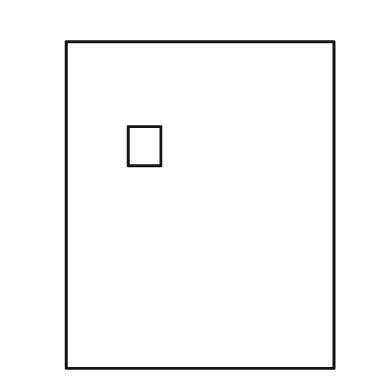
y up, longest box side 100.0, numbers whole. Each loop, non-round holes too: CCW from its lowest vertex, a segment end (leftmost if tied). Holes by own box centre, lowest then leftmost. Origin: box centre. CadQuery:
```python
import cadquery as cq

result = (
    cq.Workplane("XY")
    .moveTo(-41.0, -50.0)
    .lineTo(41.0, -50.0)
    .lineTo(41.0, 50.0)
    .lineTo(-41.0, 50.0)
    .close()
    .moveTo(-22.0, 12.0)
    .lineTo(-12.0, 12.0)
    .lineTo(-12.0, 24.0)
    .lineTo(-22.0, 24.0)
    .close()
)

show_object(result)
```